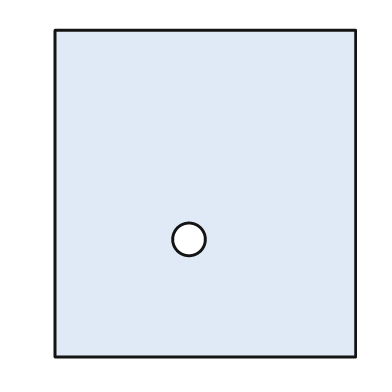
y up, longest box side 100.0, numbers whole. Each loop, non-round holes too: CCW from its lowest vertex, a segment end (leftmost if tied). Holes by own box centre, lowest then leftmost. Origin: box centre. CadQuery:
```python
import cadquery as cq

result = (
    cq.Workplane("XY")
    .moveTo(-46.0, -50.0)
    .lineTo(46.0, -50.0)
    .lineTo(46.0, 50.0)
    .lineTo(-46.0, 50.0)
    .close()
    .moveTo(-5.0, -14.0)
    .circle(5.0)
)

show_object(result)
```